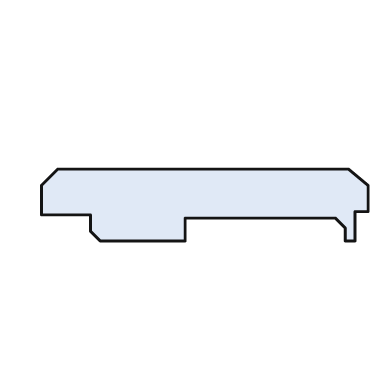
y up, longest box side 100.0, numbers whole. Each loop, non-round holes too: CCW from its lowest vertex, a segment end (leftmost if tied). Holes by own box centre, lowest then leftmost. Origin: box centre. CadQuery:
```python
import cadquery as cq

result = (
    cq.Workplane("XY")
    .moveTo(-32.0, -11.0)
    .lineTo(-6.0, -11.0)
    .lineTo(-6.0, -4.0)
    .lineTo(40.0, -4.0)
    .lineTo(43.0, -7.0)
    .lineTo(43.0, -11.0)
    .lineTo(46.0, -11.0)
    .lineTo(46.0, -2.0)
    .lineTo(50.0, -2.0)
    .lineTo(50.0, 6.0)
    .lineTo(44.0, 11.0)
    .lineTo(-45.0, 11.0)
    .lineTo(-50.0, 6.0)
    .lineTo(-50.0, -3.0)
    .lineTo(-35.0, -3.0)
    .lineTo(-35.0, -8.0)
    .close()
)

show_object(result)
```